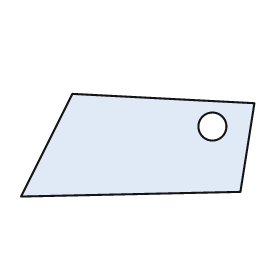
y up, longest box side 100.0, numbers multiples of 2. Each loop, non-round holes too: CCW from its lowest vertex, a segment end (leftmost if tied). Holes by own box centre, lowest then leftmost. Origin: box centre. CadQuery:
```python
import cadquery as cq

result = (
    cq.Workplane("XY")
    .moveTo(-50.0, -22.0)
    .lineTo(44.0, -20.0)
    .lineTo(50.0, 18.0)
    .lineTo(-28.0, 22.0)
    .close()
    .moveTo(32.0, 8.0)
    .circle(6.0)
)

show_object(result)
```